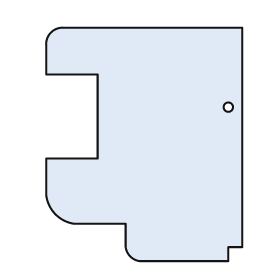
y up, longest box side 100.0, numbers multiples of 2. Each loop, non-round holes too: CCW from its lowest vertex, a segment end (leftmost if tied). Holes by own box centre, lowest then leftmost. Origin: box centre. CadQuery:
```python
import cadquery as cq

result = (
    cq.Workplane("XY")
    .moveTo(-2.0, -50.0)
    .lineTo(36.0, -50.0)
    .lineTo(36.0, -44.0)
    .lineTo(42.0, -44.0)
    .lineTo(42.0, 50.0)
    .lineTo(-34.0, 50.0)
    .threePointArc((-40.0, 48.0), (-42.0, 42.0))
    .lineTo(-42.0, 30.0)
    .lineTo(-20.0, 30.0)
    .lineTo(-20.0, -6.0)
    .lineTo(-42.0, -6.0)
    .lineTo(-42.0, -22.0)
    .threePointArc((-38.0, -30.0), (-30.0, -34.0))
    .lineTo(-8.0, -34.0)
    .lineTo(-8.0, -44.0)
    .threePointArc((-6.0, -48.0), (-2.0, -50.0))
    .close()
    .moveTo(36.0, 16.0)
    .circle(2.0)
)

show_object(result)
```